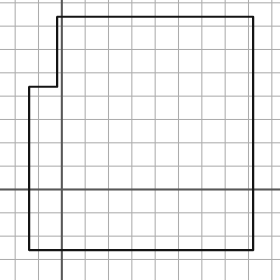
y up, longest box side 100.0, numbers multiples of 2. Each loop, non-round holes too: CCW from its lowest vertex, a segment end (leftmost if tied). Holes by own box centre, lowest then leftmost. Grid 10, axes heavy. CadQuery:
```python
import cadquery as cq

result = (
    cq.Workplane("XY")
    .moveTo(-14.0, -26.0)
    .lineTo(82.0, -26.0)
    .lineTo(82.0, 74.0)
    .lineTo(-2.0, 74.0)
    .lineTo(-2.0, 44.0)
    .lineTo(-14.0, 44.0)
    .close()
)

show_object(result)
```